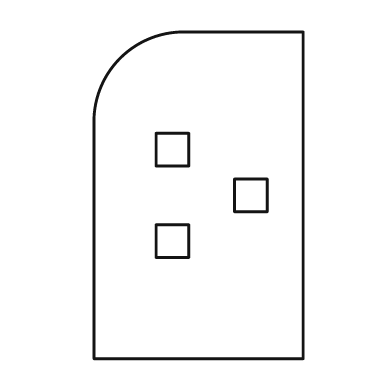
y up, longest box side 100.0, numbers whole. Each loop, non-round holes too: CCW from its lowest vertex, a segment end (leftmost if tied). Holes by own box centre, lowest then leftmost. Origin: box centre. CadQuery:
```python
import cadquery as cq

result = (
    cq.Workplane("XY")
    .moveTo(-32.0, -50.0)
    .lineTo(32.0, -50.0)
    .lineTo(32.0, 50.0)
    .lineTo(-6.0, 50.0)
    .threePointArc((-24.0, 42.0), (-32.0, 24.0))
    .close()
    .moveTo(-13.0, -19.0)
    .lineTo(-3.0, -19.0)
    .lineTo(-3.0, -9.0)
    .lineTo(-13.0, -9.0)
    .close()
    .moveTo(11.0, -5.0)
    .lineTo(21.0, -5.0)
    .lineTo(21.0, 5.0)
    .lineTo(11.0, 5.0)
    .close()
    .moveTo(-13.0, 9.0)
    .lineTo(-3.0, 9.0)
    .lineTo(-3.0, 19.0)
    .lineTo(-13.0, 19.0)
    .close()
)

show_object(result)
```